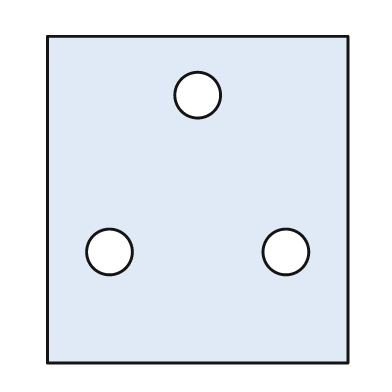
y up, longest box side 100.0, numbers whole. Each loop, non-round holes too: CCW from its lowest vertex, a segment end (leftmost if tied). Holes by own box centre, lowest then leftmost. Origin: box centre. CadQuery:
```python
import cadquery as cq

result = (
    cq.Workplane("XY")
    .moveTo(-46.0, -50.0)
    .lineTo(46.0, -50.0)
    .lineTo(46.0, 50.0)
    .lineTo(-46.0, 50.0)
    .close()
    .moveTo(-27.0, -16.0)
    .circle(7.0)
    .moveTo(27.0, -16.0)
    .circle(7.0)
    .moveTo(0.0, 32.0)
    .circle(7.0)
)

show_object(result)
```